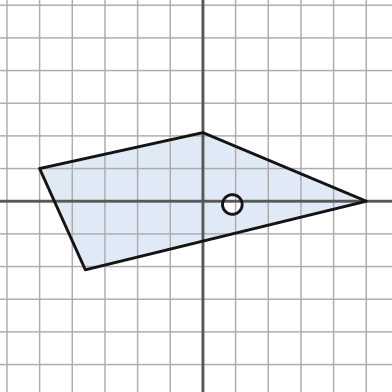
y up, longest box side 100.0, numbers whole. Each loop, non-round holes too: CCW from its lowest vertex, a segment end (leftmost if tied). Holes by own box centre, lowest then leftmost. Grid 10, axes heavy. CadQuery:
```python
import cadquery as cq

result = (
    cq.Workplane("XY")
    .moveTo(-36.0, -21.0)
    .lineTo(50.0, 0.0)
    .lineTo(0.0, 21.0)
    .lineTo(-50.0, 10.0)
    .close()
    .moveTo(9.0, -1.0)
    .circle(3.0)
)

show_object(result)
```